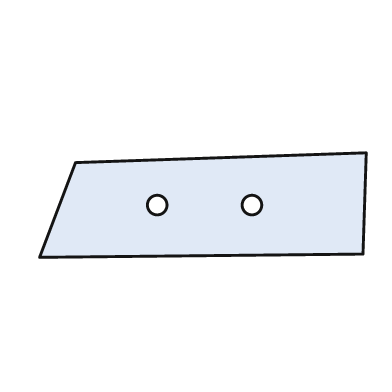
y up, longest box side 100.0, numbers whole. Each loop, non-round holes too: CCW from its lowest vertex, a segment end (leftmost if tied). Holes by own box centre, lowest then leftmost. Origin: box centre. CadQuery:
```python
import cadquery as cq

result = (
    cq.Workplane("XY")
    .moveTo(-50.0, -16.0)
    .lineTo(49.0, -15.0)
    .lineTo(50.0, 16.0)
    .lineTo(-39.0, 13.0)
    .close()
    .moveTo(-14.0, 0.0)
    .circle(3.0)
    .moveTo(15.0, 0.0)
    .circle(3.0)
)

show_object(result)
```